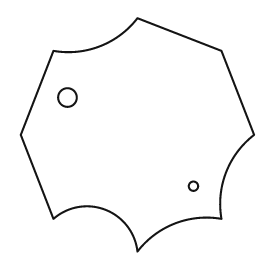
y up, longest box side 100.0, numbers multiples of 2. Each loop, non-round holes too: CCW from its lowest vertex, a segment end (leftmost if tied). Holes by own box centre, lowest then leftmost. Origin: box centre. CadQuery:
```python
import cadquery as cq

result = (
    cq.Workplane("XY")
    .moveTo(0.0, -50.0)
    .threePointArc((16.0, -38.0), (36.0, -36.0))
    .threePointArc((38.0, -16.0), (50.0, 0.0))
    .lineTo(36.0, 36.0)
    .lineTo(0.0, 50.0)
    .threePointArc((-16.0, 38.0), (-36.0, 36.0))
    .lineTo(-50.0, 0.0)
    .lineTo(-36.0, -36.0)
    .threePointArc((-14.0, -32.0), (0.0, -50.0))
    .close()
    .moveTo(24.0, -22.0)
    .circle(2.0)
    .moveTo(-30.0, 16.0)
    .circle(4.0)
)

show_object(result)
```